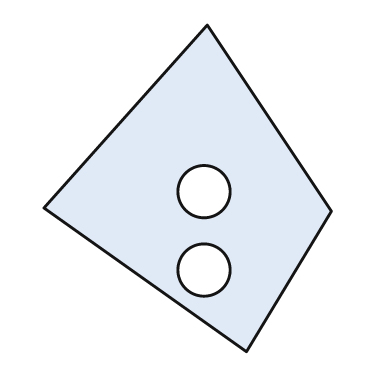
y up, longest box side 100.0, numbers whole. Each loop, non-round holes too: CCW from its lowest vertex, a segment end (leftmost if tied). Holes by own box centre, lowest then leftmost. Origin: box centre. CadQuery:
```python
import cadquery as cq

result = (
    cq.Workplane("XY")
    .moveTo(18.0, -50.0)
    .lineTo(44.0, -7.0)
    .lineTo(6.0, 50.0)
    .lineTo(-44.0, -6.0)
    .close()
    .moveTo(5.0, -25.0)
    .circle(8.0)
    .moveTo(5.0, -1.0)
    .circle(8.0)
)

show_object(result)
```